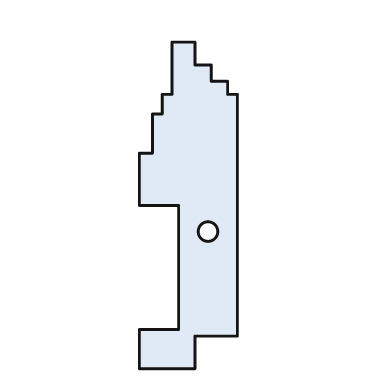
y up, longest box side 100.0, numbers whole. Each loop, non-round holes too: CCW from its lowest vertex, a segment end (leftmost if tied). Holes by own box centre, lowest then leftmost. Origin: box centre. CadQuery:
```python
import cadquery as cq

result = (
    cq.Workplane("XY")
    .moveTo(-15.0, -50.0)
    .lineTo(2.0, -50.0)
    .lineTo(2.0, -40.0)
    .lineTo(15.0, -40.0)
    .lineTo(15.0, 34.0)
    .lineTo(12.0, 34.0)
    .lineTo(12.0, 38.0)
    .lineTo(7.0, 38.0)
    .lineTo(7.0, 43.0)
    .lineTo(2.0, 43.0)
    .lineTo(2.0, 50.0)
    .lineTo(-5.0, 50.0)
    .lineTo(-5.0, 34.0)
    .lineTo(-8.0, 34.0)
    .lineTo(-8.0, 28.0)
    .lineTo(-11.0, 28.0)
    .lineTo(-11.0, 16.0)
    .lineTo(-15.0, 16.0)
    .lineTo(-15.0, 0.0)
    .lineTo(-3.0, 0.0)
    .lineTo(-3.0, -38.0)
    .lineTo(-15.0, -38.0)
    .close()
    .moveTo(6.0, -8.0)
    .circle(3.0)
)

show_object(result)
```